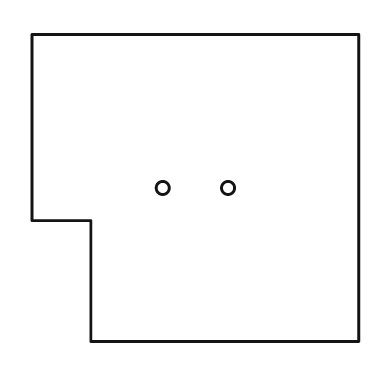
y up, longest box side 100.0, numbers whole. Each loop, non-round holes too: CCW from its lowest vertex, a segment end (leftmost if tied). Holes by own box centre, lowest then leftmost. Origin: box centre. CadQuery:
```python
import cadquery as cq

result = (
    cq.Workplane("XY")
    .moveTo(-32.0, -47.0)
    .lineTo(50.0, -47.0)
    .lineTo(50.0, 47.0)
    .lineTo(-50.0, 47.0)
    .lineTo(-50.0, -10.0)
    .lineTo(-32.0, -10.0)
    .close()
    .moveTo(-10.0, 0.0)
    .circle(2.0)
    .moveTo(10.0, 0.0)
    .circle(2.0)
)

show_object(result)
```